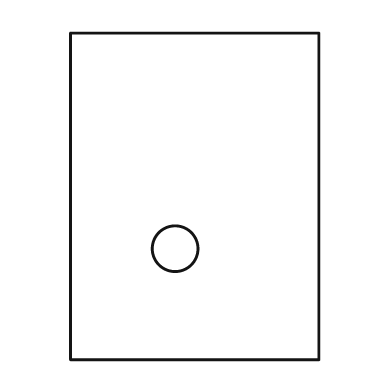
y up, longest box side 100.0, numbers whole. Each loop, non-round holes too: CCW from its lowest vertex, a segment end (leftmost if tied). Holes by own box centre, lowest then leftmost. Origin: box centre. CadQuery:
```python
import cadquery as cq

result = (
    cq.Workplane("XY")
    .moveTo(-38.0, -50.0)
    .lineTo(38.0, -50.0)
    .lineTo(38.0, 50.0)
    .lineTo(-38.0, 50.0)
    .close()
    .moveTo(-6.0, -16.0)
    .circle(7.0)
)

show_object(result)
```